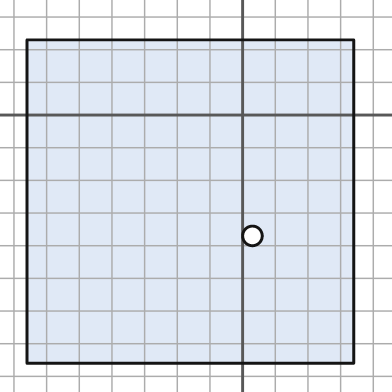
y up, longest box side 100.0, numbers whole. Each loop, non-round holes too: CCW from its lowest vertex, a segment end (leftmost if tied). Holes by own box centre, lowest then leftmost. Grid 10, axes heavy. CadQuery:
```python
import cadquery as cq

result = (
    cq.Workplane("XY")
    .moveTo(-66.0, -76.0)
    .lineTo(34.0, -76.0)
    .lineTo(34.0, 23.0)
    .lineTo(-66.0, 23.0)
    .close()
    .moveTo(3.0, -37.0)
    .circle(3.0)
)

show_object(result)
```